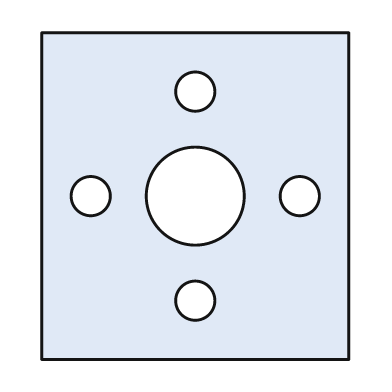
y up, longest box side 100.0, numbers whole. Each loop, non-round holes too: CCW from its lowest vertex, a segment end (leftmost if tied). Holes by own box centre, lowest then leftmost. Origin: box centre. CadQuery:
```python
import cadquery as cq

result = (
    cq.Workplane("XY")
    .moveTo(-47.0, -50.0)
    .lineTo(47.0, -50.0)
    .lineTo(47.0, 50.0)
    .lineTo(-47.0, 50.0)
    .close()
    .moveTo(0.0, -32.0)
    .circle(6.0)
    .moveTo(-32.0, 0.0)
    .circle(6.0)
    .moveTo(0.0, 0.0)
    .circle(15.0)
    .moveTo(32.0, 0.0)
    .circle(6.0)
    .moveTo(0.0, 32.0)
    .circle(6.0)
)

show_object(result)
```